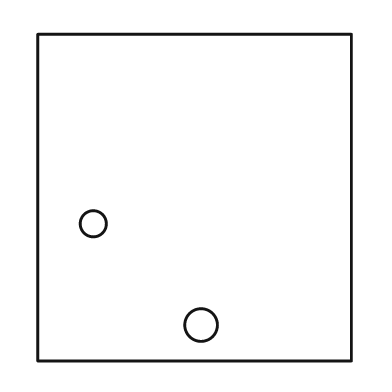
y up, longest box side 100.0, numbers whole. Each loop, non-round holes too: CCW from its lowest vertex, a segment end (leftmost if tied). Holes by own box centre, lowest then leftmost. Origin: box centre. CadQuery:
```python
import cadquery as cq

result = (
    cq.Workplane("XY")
    .moveTo(-48.0, -50.0)
    .lineTo(48.0, -50.0)
    .lineTo(48.0, 50.0)
    .lineTo(-48.0, 50.0)
    .close()
    .moveTo(2.0, -39.0)
    .circle(5.0)
    .moveTo(-31.0, -8.0)
    .circle(4.0)
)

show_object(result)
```